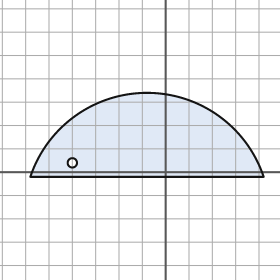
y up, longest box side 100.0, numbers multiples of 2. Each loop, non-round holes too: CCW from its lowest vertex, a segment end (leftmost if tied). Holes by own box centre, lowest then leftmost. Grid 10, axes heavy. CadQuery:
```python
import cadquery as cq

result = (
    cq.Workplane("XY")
    .moveTo(-58.0, -2.0)
    .lineTo(42.0, -2.0)
    .threePointArc((-8.0, 34.0), (-58.0, -2.0))
    .close()
    .moveTo(-40.0, 4.0)
    .circle(2.0)
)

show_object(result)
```